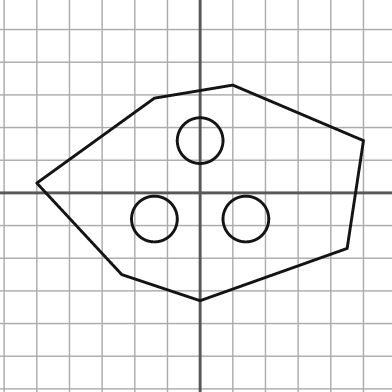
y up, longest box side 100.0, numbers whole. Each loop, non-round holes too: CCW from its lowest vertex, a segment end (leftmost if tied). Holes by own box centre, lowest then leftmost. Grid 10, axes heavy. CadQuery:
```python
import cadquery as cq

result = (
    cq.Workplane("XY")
    .moveTo(0.0, -33.0)
    .lineTo(45.0, -17.0)
    .lineTo(50.0, 16.0)
    .lineTo(10.0, 33.0)
    .lineTo(-14.0, 29.0)
    .lineTo(-50.0, 3.0)
    .lineTo(-24.0, -25.0)
    .close()
    .moveTo(-14.0, -8.0)
    .circle(7.0)
    .moveTo(14.0, -8.0)
    .circle(7.0)
    .moveTo(0.0, 16.0)
    .circle(7.0)
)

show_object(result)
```